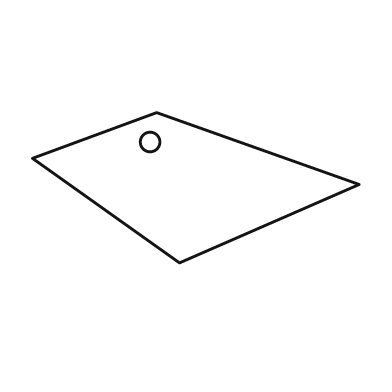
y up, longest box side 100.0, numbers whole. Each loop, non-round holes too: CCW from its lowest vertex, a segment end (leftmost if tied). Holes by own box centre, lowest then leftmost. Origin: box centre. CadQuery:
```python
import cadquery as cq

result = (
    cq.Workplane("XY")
    .moveTo(-5.0, -23.0)
    .lineTo(50.0, 1.0)
    .lineTo(-12.0, 23.0)
    .lineTo(-50.0, 9.0)
    .close()
    .moveTo(-14.0, 14.0)
    .circle(3.0)
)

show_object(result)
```